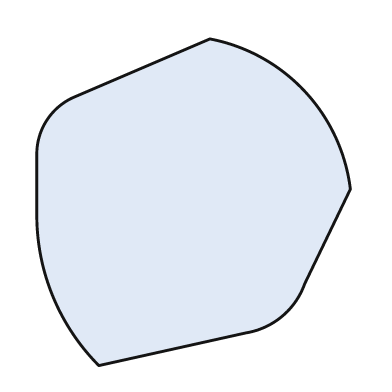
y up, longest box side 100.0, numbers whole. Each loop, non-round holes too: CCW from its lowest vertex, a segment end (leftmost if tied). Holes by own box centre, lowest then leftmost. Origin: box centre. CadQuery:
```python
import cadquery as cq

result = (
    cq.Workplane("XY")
    .moveTo(-29.0, -50.0)
    .lineTo(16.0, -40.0)
    .threePointArc((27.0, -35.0), (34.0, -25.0))
    .lineTo(48.0, 4.0)
    .threePointArc((34.0, 34.0), (5.0, 50.0))
    .lineTo(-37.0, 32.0)
    .threePointArc((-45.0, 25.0), (-48.0, 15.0))
    .lineTo(-48.0, -4.0)
    .threePointArc((-43.0, -29.0), (-29.0, -50.0))
    .close()
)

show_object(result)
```